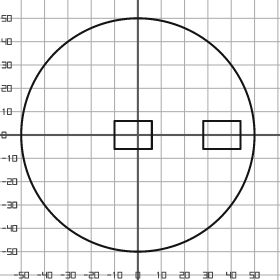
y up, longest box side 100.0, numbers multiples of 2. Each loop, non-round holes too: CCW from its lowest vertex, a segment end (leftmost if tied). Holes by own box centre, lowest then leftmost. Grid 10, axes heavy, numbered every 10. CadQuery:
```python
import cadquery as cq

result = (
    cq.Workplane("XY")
    .moveTo(0.0, 0.0)
    .circle(50.0)
    .moveTo(-10.0, -6.0)
    .lineTo(6.0, -6.0)
    .lineTo(6.0, 6.0)
    .lineTo(-10.0, 6.0)
    .close()
    .moveTo(28.0, -6.0)
    .lineTo(44.0, -6.0)
    .lineTo(44.0, 6.0)
    .lineTo(28.0, 6.0)
    .close()
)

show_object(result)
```